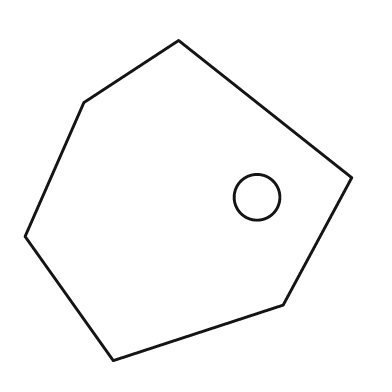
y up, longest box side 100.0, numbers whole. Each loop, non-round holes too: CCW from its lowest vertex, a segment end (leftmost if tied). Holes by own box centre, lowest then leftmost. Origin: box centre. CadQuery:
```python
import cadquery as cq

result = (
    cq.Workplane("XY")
    .moveTo(-23.0, -49.0)
    .lineTo(29.0, -32.0)
    .lineTo(50.0, 7.0)
    .lineTo(-3.0, 49.0)
    .lineTo(-32.0, 30.0)
    .lineTo(-50.0, -11.0)
    .close()
    .moveTo(21.0, 1.0)
    .circle(7.0)
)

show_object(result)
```